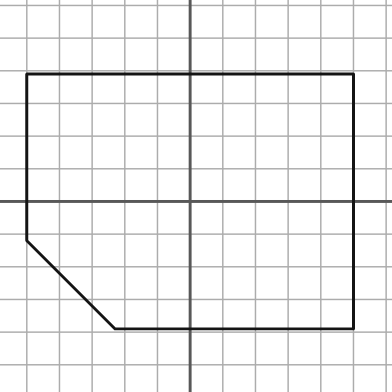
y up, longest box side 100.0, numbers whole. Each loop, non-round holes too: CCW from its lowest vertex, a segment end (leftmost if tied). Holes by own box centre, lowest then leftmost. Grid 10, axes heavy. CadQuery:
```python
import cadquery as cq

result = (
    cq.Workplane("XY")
    .moveTo(-23.0, -39.0)
    .lineTo(50.0, -39.0)
    .lineTo(50.0, 39.0)
    .lineTo(-50.0, 39.0)
    .lineTo(-50.0, -12.0)
    .close()
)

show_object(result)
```